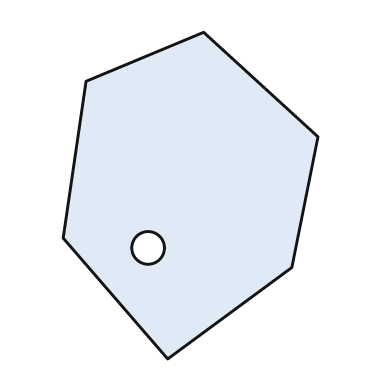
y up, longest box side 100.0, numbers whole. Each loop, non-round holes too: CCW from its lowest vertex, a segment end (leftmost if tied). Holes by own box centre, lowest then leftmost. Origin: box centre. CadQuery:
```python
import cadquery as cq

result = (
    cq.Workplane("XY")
    .moveTo(-7.0, -50.0)
    .lineTo(31.0, -22.0)
    .lineTo(39.0, 18.0)
    .lineTo(4.0, 50.0)
    .lineTo(-32.0, 35.0)
    .lineTo(-39.0, -13.0)
    .close()
    .moveTo(-13.0, -16.0)
    .circle(5.0)
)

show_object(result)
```